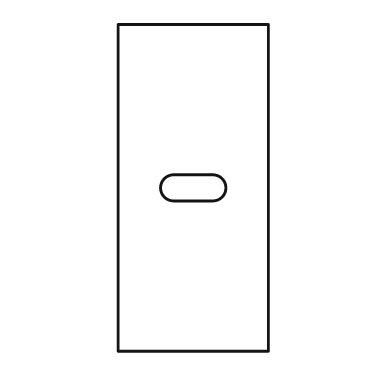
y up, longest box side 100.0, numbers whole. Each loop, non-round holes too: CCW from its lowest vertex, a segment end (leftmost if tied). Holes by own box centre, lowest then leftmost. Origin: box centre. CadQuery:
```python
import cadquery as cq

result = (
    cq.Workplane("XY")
    .moveTo(-23.0, -50.0)
    .lineTo(23.0, -50.0)
    .lineTo(23.0, 50.0)
    .lineTo(-23.0, 50.0)
    .close()
    .moveTo(-6.0, -4.0)
    .lineTo(6.0, -4.0)
    .threePointArc((10.0, 0.0), (6.0, 4.0))
    .lineTo(-6.0, 4.0)
    .threePointArc((-10.0, 0.0), (-6.0, -4.0))
    .close()
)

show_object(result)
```